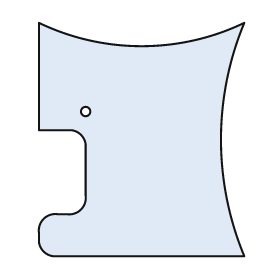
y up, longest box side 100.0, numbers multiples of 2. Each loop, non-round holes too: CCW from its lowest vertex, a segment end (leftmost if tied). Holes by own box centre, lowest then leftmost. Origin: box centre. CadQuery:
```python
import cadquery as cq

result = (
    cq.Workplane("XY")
    .moveTo(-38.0, -50.0)
    .lineTo(44.0, -50.0)
    .threePointArc((34.0, 0.0), (44.0, 50.0))
    .threePointArc((0.0, 40.0), (-44.0, 50.0))
    .lineTo(-44.0, 4.0)
    .lineTo(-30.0, 4.0)
    .threePointArc((-26.0, 2.0), (-24.0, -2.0))
    .lineTo(-24.0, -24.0)
    .threePointArc((-26.0, -30.0), (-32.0, -32.0))
    .lineTo(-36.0, -32.0)
    .threePointArc((-42.0, -34.0), (-44.0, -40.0))
    .lineTo(-44.0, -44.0)
    .threePointArc((-42.0, -48.0), (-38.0, -50.0))
    .close()
    .moveTo(-24.0, 12.0)
    .circle(2.0)
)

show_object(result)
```